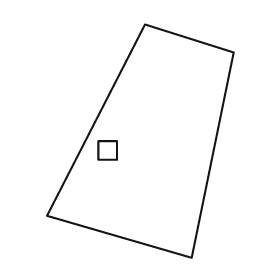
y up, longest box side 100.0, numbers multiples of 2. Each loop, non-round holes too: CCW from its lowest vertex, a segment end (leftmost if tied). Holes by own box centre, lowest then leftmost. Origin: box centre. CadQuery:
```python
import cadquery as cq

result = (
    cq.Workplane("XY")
    .moveTo(22.0, -50.0)
    .lineTo(40.0, 38.0)
    .lineTo(2.0, 50.0)
    .lineTo(-40.0, -32.0)
    .close()
    .moveTo(-18.0, -8.0)
    .lineTo(-10.0, -8.0)
    .lineTo(-10.0, 0.0)
    .lineTo(-18.0, 0.0)
    .close()
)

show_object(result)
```